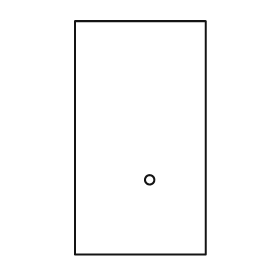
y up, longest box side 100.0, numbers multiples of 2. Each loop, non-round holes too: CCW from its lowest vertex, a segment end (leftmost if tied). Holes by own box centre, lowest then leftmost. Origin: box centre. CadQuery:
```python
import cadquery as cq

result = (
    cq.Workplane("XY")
    .moveTo(-28.0, -50.0)
    .lineTo(28.0, -50.0)
    .lineTo(28.0, 50.0)
    .lineTo(-28.0, 50.0)
    .close()
    .moveTo(4.0, -18.0)
    .circle(2.0)
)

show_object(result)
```